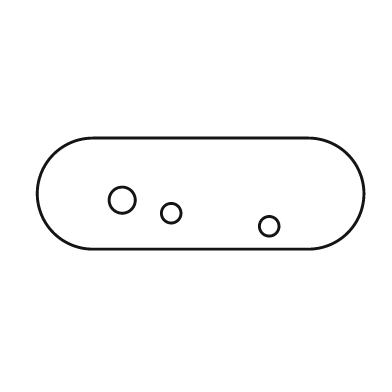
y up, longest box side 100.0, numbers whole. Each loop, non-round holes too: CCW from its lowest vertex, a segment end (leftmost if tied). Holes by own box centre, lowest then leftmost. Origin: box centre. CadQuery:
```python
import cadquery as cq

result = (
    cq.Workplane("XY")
    .moveTo(-33.0, -17.0)
    .lineTo(33.0, -17.0)
    .threePointArc((50.0, 0.0), (33.0, 17.0))
    .lineTo(-33.0, 17.0)
    .threePointArc((-50.0, 0.0), (-33.0, -17.0))
    .close()
    .moveTo(21.0, -10.0)
    .circle(3.0)
    .moveTo(-9.0, -6.0)
    .circle(3.0)
    .moveTo(-24.0, -2.0)
    .circle(4.0)
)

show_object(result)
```